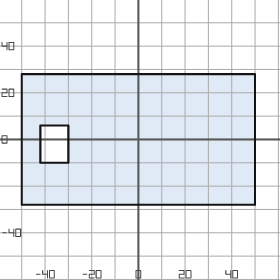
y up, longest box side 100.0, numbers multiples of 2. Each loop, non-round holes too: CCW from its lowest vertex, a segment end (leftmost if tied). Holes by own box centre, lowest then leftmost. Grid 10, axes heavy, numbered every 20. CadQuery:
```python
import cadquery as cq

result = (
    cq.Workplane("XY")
    .moveTo(-50.0, -28.0)
    .lineTo(50.0, -28.0)
    .lineTo(50.0, 28.0)
    .lineTo(-50.0, 28.0)
    .close()
    .moveTo(-42.0, -10.0)
    .lineTo(-30.0, -10.0)
    .lineTo(-30.0, 6.0)
    .lineTo(-42.0, 6.0)
    .close()
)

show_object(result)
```